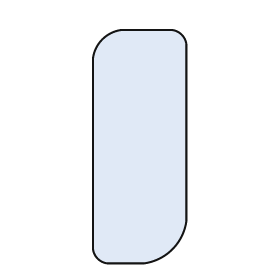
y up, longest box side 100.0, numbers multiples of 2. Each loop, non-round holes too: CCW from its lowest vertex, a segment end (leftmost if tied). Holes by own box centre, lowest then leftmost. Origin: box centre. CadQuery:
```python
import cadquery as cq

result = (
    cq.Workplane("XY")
    .moveTo(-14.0, -50.0)
    .lineTo(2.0, -50.0)
    .threePointArc((14.0, -44.0), (20.0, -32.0))
    .lineTo(20.0, 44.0)
    .threePointArc((18.0, 48.0), (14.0, 50.0))
    .lineTo(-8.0, 50.0)
    .threePointArc((-16.0, 46.0), (-20.0, 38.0))
    .lineTo(-20.0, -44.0)
    .threePointArc((-18.0, -48.0), (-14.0, -50.0))
    .close()
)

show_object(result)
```